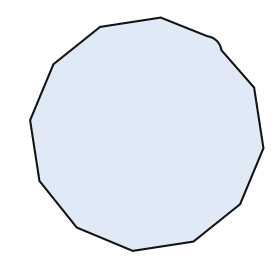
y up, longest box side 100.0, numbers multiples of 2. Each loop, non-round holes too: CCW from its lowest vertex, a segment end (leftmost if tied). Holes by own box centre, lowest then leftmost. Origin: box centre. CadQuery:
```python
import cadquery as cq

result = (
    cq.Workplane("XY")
    .moveTo(-6.0, -50.0)
    .lineTo(20.0, -46.0)
    .lineTo(40.0, -30.0)
    .lineTo(50.0, -6.0)
    .lineTo(46.0, 20.0)
    .lineTo(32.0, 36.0)
    .threePointArc((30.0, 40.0), (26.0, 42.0))
    .lineTo(6.0, 50.0)
    .lineTo(-20.0, 46.0)
    .lineTo(-40.0, 30.0)
    .lineTo(-50.0, 6.0)
    .lineTo(-46.0, -20.0)
    .lineTo(-30.0, -40.0)
    .close()
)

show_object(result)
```